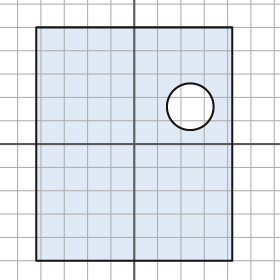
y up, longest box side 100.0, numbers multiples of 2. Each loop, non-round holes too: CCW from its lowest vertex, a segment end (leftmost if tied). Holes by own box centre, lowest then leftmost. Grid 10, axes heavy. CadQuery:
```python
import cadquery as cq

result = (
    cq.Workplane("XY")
    .moveTo(-42.0, -50.0)
    .lineTo(42.0, -50.0)
    .lineTo(42.0, 50.0)
    .lineTo(-42.0, 50.0)
    .close()
    .moveTo(24.0, 16.0)
    .circle(10.0)
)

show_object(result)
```